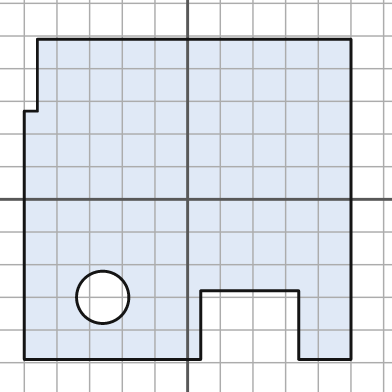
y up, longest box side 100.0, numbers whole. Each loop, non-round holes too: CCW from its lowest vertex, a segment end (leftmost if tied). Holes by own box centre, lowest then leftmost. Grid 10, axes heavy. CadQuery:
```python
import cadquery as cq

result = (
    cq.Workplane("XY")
    .moveTo(-50.0, -49.0)
    .lineTo(4.0, -49.0)
    .lineTo(4.0, -28.0)
    .lineTo(34.0, -28.0)
    .lineTo(34.0, -49.0)
    .lineTo(50.0, -49.0)
    .lineTo(50.0, 49.0)
    .lineTo(-46.0, 49.0)
    .lineTo(-46.0, 27.0)
    .lineTo(-50.0, 27.0)
    .close()
    .moveTo(-26.0, -30.0)
    .circle(8.0)
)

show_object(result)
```